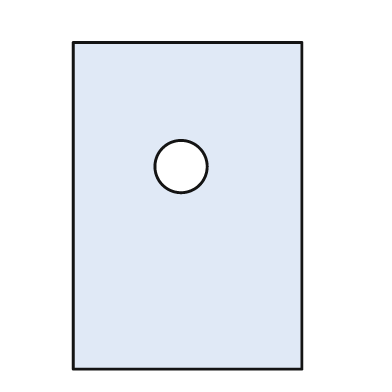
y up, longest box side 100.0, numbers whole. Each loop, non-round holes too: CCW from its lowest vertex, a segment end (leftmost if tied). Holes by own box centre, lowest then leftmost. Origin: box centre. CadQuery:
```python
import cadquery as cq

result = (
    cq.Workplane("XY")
    .moveTo(-35.0, -50.0)
    .lineTo(35.0, -50.0)
    .lineTo(35.0, 50.0)
    .lineTo(-35.0, 50.0)
    .close()
    .moveTo(-2.0, 12.0)
    .circle(8.0)
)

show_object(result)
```